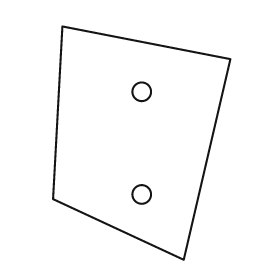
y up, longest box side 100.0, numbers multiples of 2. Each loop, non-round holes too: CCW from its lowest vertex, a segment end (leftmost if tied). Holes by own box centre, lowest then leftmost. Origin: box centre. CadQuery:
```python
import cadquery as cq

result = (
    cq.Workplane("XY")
    .moveTo(18.0, -50.0)
    .lineTo(38.0, 36.0)
    .lineTo(-34.0, 50.0)
    .lineTo(-38.0, -24.0)
    .close()
    .moveTo(0.0, -22.0)
    .circle(4.0)
    .moveTo(0.0, 22.0)
    .circle(4.0)
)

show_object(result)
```